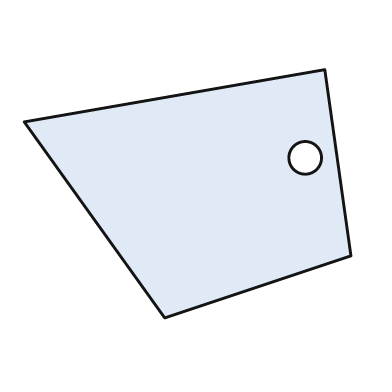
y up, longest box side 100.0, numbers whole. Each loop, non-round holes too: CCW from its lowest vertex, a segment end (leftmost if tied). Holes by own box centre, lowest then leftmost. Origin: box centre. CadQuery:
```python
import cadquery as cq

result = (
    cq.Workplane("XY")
    .moveTo(-7.0, -38.0)
    .lineTo(50.0, -19.0)
    .lineTo(42.0, 38.0)
    .lineTo(-50.0, 22.0)
    .close()
    .moveTo(36.0, 11.0)
    .circle(5.0)
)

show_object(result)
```